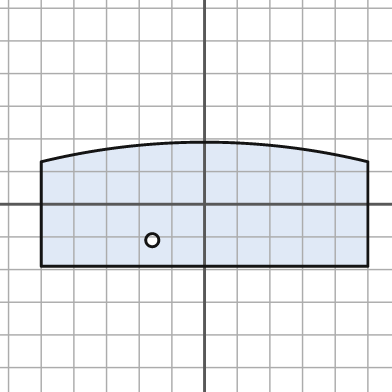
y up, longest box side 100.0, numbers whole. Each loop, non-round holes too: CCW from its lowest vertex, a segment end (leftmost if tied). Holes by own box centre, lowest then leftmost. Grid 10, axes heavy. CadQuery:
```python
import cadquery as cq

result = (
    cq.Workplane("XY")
    .moveTo(-50.0, -19.0)
    .lineTo(50.0, -19.0)
    .lineTo(50.0, 13.0)
    .threePointArc((0.0, 19.0), (-50.0, 13.0))
    .close()
    .moveTo(-16.0, -11.0)
    .circle(2.0)
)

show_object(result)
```